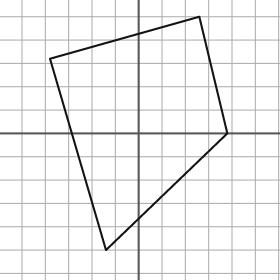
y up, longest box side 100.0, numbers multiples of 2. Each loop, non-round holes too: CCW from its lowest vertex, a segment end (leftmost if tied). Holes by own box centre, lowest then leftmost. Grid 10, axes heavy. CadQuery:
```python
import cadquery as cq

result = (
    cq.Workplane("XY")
    .moveTo(-14.0, -50.0)
    .lineTo(38.0, 0.0)
    .lineTo(26.0, 50.0)
    .lineTo(-38.0, 32.0)
    .close()
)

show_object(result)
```